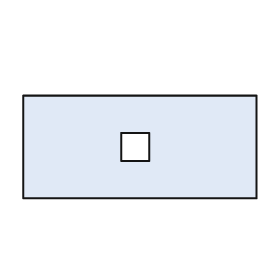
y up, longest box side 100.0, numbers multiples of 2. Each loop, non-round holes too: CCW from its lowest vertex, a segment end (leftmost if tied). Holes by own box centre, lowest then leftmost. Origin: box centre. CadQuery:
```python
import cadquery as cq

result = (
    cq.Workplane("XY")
    .moveTo(-50.0, -22.0)
    .lineTo(50.0, -22.0)
    .lineTo(50.0, 22.0)
    .lineTo(-50.0, 22.0)
    .close()
    .moveTo(-8.0, -6.0)
    .lineTo(4.0, -6.0)
    .lineTo(4.0, 6.0)
    .lineTo(-8.0, 6.0)
    .close()
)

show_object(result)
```